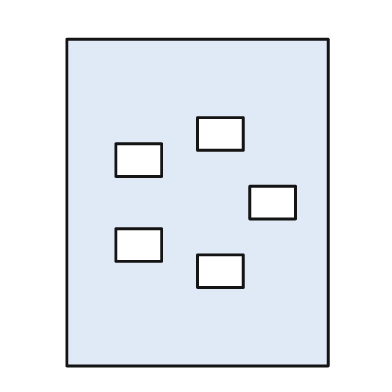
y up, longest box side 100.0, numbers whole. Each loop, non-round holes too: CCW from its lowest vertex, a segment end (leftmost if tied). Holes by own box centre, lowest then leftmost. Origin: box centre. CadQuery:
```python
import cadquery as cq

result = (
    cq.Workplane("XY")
    .moveTo(-40.0, -50.0)
    .lineTo(40.0, -50.0)
    .lineTo(40.0, 50.0)
    .lineTo(-40.0, 50.0)
    .close()
    .moveTo(0.0, -26.0)
    .lineTo(14.0, -26.0)
    .lineTo(14.0, -16.0)
    .lineTo(0.0, -16.0)
    .close()
    .moveTo(-25.0, -18.0)
    .lineTo(-11.0, -18.0)
    .lineTo(-11.0, -8.0)
    .lineTo(-25.0, -8.0)
    .close()
    .moveTo(16.0, -5.0)
    .lineTo(30.0, -5.0)
    .lineTo(30.0, 5.0)
    .lineTo(16.0, 5.0)
    .close()
    .moveTo(-25.0, 8.0)
    .lineTo(-11.0, 8.0)
    .lineTo(-11.0, 18.0)
    .lineTo(-25.0, 18.0)
    .close()
    .moveTo(0.0, 16.0)
    .lineTo(14.0, 16.0)
    .lineTo(14.0, 26.0)
    .lineTo(0.0, 26.0)
    .close()
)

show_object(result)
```